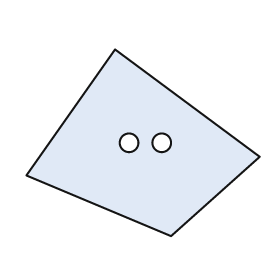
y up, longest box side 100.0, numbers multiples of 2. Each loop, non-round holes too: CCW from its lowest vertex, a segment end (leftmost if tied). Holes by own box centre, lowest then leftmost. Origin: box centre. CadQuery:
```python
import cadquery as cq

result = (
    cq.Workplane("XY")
    .moveTo(12.0, -40.0)
    .lineTo(50.0, -6.0)
    .lineTo(-12.0, 40.0)
    .lineTo(-50.0, -14.0)
    .close()
    .moveTo(-6.0, 0.0)
    .circle(4.0)
    .moveTo(8.0, 0.0)
    .circle(4.0)
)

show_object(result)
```